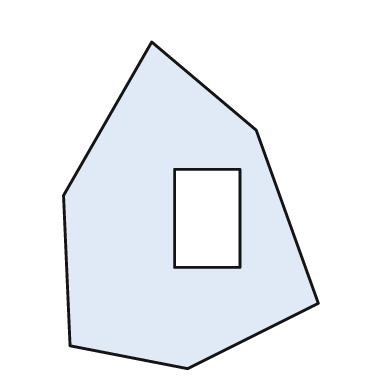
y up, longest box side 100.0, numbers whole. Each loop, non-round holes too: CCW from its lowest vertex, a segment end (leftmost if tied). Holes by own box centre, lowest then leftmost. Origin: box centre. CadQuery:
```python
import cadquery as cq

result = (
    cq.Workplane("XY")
    .moveTo(-1.0, -50.0)
    .lineTo(39.0, -30.0)
    .lineTo(20.0, 23.0)
    .lineTo(-12.0, 50.0)
    .lineTo(-39.0, 3.0)
    .lineTo(-37.0, -43.0)
    .close()
    .moveTo(-5.0, -19.0)
    .lineTo(15.0, -19.0)
    .lineTo(15.0, 11.0)
    .lineTo(-5.0, 11.0)
    .close()
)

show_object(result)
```